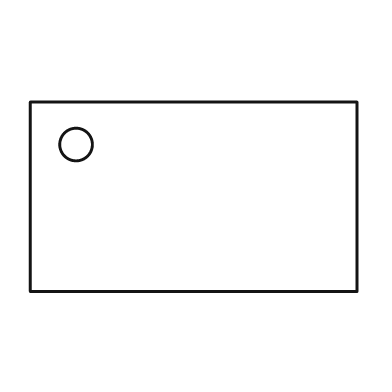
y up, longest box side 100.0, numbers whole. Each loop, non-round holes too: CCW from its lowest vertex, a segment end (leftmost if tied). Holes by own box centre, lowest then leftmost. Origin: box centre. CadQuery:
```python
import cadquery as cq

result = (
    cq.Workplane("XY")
    .moveTo(-50.0, -29.0)
    .lineTo(50.0, -29.0)
    .lineTo(50.0, 29.0)
    .lineTo(-50.0, 29.0)
    .close()
    .moveTo(-36.0, 16.0)
    .circle(5.0)
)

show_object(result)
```